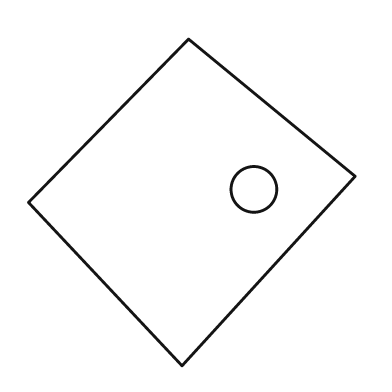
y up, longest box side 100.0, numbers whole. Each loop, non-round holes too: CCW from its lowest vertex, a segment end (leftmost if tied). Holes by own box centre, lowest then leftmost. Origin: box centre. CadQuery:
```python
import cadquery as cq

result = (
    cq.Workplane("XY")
    .moveTo(-3.0, -50.0)
    .lineTo(50.0, 8.0)
    .lineTo(-1.0, 50.0)
    .lineTo(-50.0, 0.0)
    .close()
    .moveTo(19.0, 4.0)
    .circle(7.0)
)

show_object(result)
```